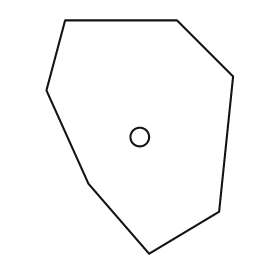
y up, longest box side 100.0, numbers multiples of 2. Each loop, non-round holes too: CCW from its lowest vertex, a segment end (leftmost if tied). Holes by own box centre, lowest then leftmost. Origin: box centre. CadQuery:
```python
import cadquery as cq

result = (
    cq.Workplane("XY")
    .moveTo(4.0, -50.0)
    .lineTo(34.0, -32.0)
    .lineTo(40.0, 26.0)
    .lineTo(16.0, 50.0)
    .lineTo(-32.0, 50.0)
    .lineTo(-40.0, 20.0)
    .lineTo(-22.0, -20.0)
    .close()
    .moveTo(0.0, 0.0)
    .circle(4.0)
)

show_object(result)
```